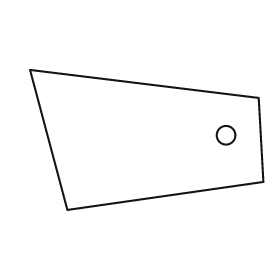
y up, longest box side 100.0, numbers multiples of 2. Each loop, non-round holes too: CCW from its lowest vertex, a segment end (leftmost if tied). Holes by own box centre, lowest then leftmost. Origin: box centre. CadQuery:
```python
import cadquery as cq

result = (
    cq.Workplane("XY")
    .moveTo(-34.0, -30.0)
    .lineTo(50.0, -18.0)
    .lineTo(48.0, 18.0)
    .lineTo(-50.0, 30.0)
    .close()
    .moveTo(34.0, 2.0)
    .circle(4.0)
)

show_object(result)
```